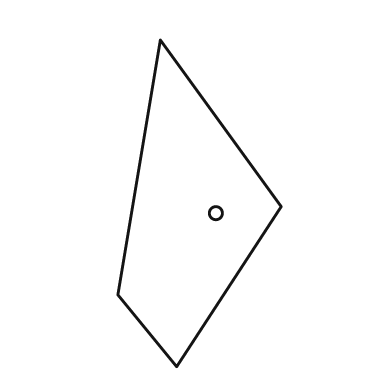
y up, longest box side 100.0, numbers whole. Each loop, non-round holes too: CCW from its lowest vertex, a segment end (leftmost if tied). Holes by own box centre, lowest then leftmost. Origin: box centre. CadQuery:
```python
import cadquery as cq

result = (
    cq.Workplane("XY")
    .moveTo(-7.0, -50.0)
    .lineTo(25.0, -1.0)
    .lineTo(-12.0, 50.0)
    .lineTo(-25.0, -28.0)
    .close()
    .moveTo(5.0, -3.0)
    .circle(2.0)
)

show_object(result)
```